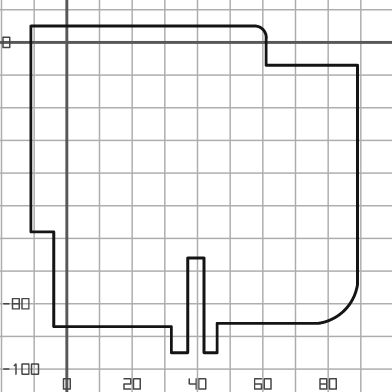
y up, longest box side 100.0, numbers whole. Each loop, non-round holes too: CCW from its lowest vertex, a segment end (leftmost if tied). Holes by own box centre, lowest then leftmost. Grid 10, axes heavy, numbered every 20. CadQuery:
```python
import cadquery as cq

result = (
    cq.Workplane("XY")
    .moveTo(32.0, -95.0)
    .lineTo(37.0, -95.0)
    .lineTo(37.0, -66.0)
    .lineTo(42.0, -66.0)
    .lineTo(42.0, -95.0)
    .lineTo(46.0, -95.0)
    .lineTo(46.0, -86.0)
    .lineTo(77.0, -86.0)
    .threePointArc((85.0, -82.0), (89.0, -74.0))
    .lineTo(89.0, -7.0)
    .lineTo(61.0, -7.0)
    .lineTo(61.0, 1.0)
    .threePointArc((60.0, 4.0), (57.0, 5.0))
    .lineTo(-11.0, 5.0)
    .lineTo(-11.0, -58.0)
    .lineTo(-4.0, -58.0)
    .lineTo(-4.0, -87.0)
    .lineTo(32.0, -87.0)
    .close()
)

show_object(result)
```